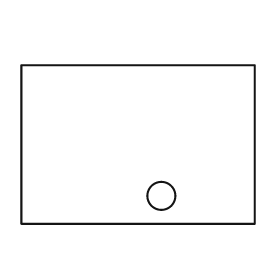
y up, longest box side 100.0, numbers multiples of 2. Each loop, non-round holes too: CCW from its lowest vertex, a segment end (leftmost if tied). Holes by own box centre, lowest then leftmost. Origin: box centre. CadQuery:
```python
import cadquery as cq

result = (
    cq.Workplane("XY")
    .moveTo(-50.0, -34.0)
    .lineTo(50.0, -34.0)
    .lineTo(50.0, 34.0)
    .lineTo(-50.0, 34.0)
    .close()
    .moveTo(10.0, -22.0)
    .circle(6.0)
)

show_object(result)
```